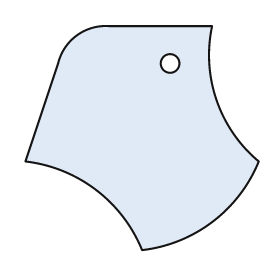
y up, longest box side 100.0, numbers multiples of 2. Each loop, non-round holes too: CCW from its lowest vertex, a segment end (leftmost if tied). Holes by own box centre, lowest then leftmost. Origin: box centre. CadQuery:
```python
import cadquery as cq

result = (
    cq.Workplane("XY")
    .moveTo(0.0, -48.0)
    .threePointArc((30.0, -36.0), (50.0, -10.0))
    .threePointArc((32.0, 16.0), (30.0, 48.0))
    .lineTo(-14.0, 48.0)
    .threePointArc((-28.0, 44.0), (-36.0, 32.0))
    .lineTo(-50.0, -10.0)
    .threePointArc((-20.0, -22.0), (0.0, -48.0))
    .close()
    .moveTo(12.0, 32.0)
    .circle(4.0)
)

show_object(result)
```